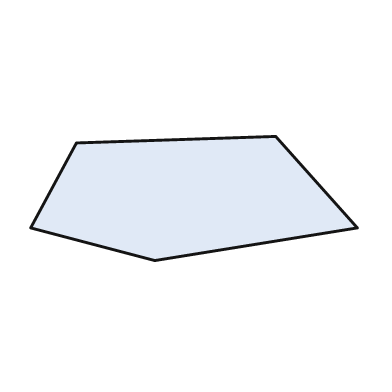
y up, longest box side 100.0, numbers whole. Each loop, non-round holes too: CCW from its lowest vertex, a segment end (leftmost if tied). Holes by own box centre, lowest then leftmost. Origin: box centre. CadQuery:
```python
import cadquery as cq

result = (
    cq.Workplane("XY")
    .moveTo(-12.0, -19.0)
    .lineTo(50.0, -9.0)
    .lineTo(25.0, 19.0)
    .lineTo(-36.0, 17.0)
    .lineTo(-50.0, -9.0)
    .close()
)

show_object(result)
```